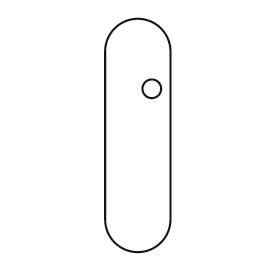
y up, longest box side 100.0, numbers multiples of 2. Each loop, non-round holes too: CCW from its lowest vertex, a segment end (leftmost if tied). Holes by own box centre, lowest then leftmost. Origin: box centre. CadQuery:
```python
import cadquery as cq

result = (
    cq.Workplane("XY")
    .moveTo(-14.0, -36.0)
    .threePointArc((0.0, -50.0), (14.0, -36.0))
    .lineTo(14.0, 36.0)
    .threePointArc((0.0, 50.0), (-14.0, 36.0))
    .close()
    .moveTo(6.0, 20.0)
    .circle(4.0)
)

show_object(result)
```